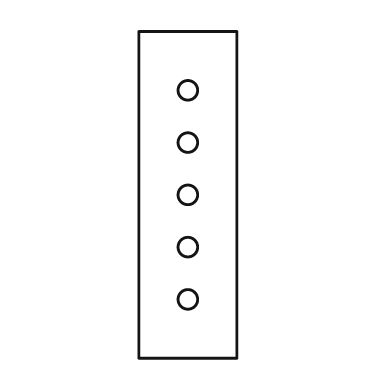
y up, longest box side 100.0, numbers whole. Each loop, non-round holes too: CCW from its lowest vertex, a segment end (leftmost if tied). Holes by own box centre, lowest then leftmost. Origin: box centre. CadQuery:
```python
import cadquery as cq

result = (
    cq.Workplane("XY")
    .moveTo(-15.0, -50.0)
    .lineTo(15.0, -50.0)
    .lineTo(15.0, 50.0)
    .lineTo(-15.0, 50.0)
    .close()
    .moveTo(0.0, -32.0)
    .circle(3.0)
    .moveTo(0.0, -16.0)
    .circle(3.0)
    .moveTo(0.0, 0.0)
    .circle(3.0)
    .moveTo(0.0, 16.0)
    .circle(3.0)
    .moveTo(0.0, 32.0)
    .circle(3.0)
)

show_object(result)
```